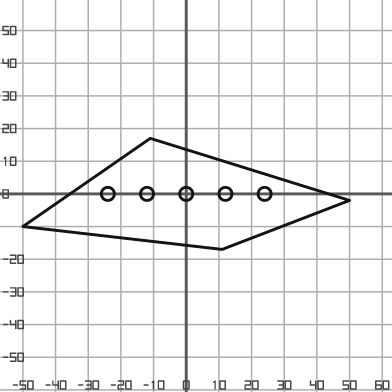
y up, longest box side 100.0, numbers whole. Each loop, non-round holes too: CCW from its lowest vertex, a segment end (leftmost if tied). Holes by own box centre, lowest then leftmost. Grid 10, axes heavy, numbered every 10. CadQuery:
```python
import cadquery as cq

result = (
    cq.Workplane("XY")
    .moveTo(11.0, -17.0)
    .lineTo(50.0, -2.0)
    .lineTo(-11.0, 17.0)
    .lineTo(-50.0, -10.0)
    .close()
    .moveTo(-24.0, 0.0)
    .circle(2.0)
    .moveTo(-12.0, 0.0)
    .circle(2.0)
    .moveTo(0.0, 0.0)
    .circle(2.0)
    .moveTo(12.0, 0.0)
    .circle(2.0)
    .moveTo(24.0, 0.0)
    .circle(2.0)
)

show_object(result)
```